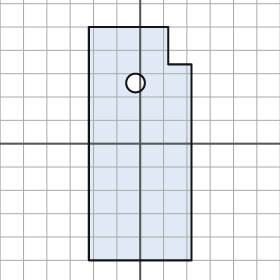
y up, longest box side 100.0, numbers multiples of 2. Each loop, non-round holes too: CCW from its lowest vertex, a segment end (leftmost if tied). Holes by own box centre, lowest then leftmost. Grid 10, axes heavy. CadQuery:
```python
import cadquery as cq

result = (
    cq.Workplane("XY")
    .moveTo(-22.0, -50.0)
    .lineTo(22.0, -50.0)
    .lineTo(22.0, 34.0)
    .lineTo(12.0, 34.0)
    .lineTo(12.0, 50.0)
    .lineTo(-22.0, 50.0)
    .close()
    .moveTo(-2.0, 26.0)
    .circle(4.0)
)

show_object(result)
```